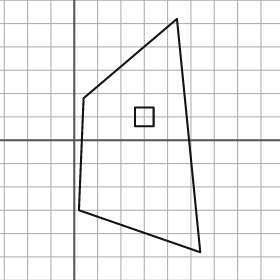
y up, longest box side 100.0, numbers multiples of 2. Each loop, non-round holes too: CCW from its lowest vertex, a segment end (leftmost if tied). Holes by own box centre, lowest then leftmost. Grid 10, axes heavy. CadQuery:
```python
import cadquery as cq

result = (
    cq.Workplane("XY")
    .moveTo(54.0, -48.0)
    .lineTo(44.0, 52.0)
    .lineTo(4.0, 18.0)
    .lineTo(2.0, -30.0)
    .close()
    .moveTo(26.0, 6.0)
    .lineTo(34.0, 6.0)
    .lineTo(34.0, 14.0)
    .lineTo(26.0, 14.0)
    .close()
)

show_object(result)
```